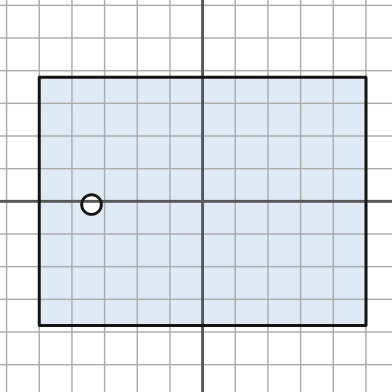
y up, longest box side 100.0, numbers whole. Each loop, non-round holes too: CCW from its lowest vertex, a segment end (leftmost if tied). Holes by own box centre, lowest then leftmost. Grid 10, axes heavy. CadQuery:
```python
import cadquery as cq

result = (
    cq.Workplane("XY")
    .moveTo(-50.0, -38.0)
    .lineTo(50.0, -38.0)
    .lineTo(50.0, 38.0)
    .lineTo(-50.0, 38.0)
    .close()
    .moveTo(-34.0, -1.0)
    .circle(3.0)
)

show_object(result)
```